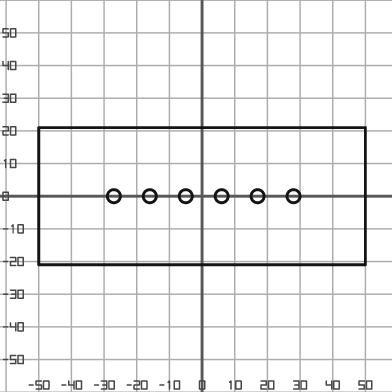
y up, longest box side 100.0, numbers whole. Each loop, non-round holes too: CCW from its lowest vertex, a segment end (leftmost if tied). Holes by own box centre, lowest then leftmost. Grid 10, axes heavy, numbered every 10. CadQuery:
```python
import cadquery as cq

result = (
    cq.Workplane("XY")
    .moveTo(-50.0, -21.0)
    .lineTo(50.0, -21.0)
    .lineTo(50.0, 21.0)
    .lineTo(-50.0, 21.0)
    .close()
    .moveTo(-27.0, 0.0)
    .circle(2.0)
    .moveTo(-16.0, 0.0)
    .circle(2.0)
    .moveTo(-5.0, 0.0)
    .circle(2.0)
    .moveTo(6.0, 0.0)
    .circle(2.0)
    .moveTo(17.0, 0.0)
    .circle(2.0)
    .moveTo(28.0, 0.0)
    .circle(2.0)
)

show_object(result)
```